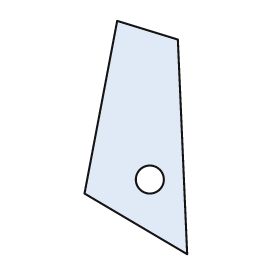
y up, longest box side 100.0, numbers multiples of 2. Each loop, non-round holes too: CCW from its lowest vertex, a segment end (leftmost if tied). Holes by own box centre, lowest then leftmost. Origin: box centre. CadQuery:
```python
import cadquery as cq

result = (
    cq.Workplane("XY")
    .moveTo(22.0, -50.0)
    .lineTo(18.0, 42.0)
    .lineTo(-8.0, 50.0)
    .lineTo(-22.0, -24.0)
    .close()
    .moveTo(6.0, -18.0)
    .circle(6.0)
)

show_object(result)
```